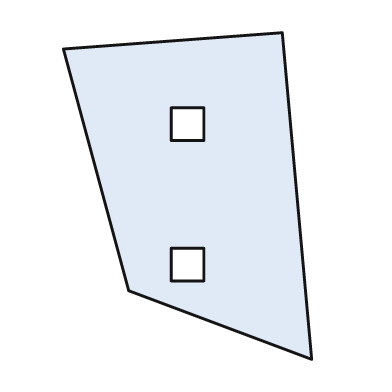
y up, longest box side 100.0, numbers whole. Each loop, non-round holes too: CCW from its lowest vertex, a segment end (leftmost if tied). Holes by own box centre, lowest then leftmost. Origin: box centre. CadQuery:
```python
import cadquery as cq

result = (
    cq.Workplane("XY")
    .moveTo(38.0, -50.0)
    .lineTo(29.0, 50.0)
    .lineTo(-38.0, 45.0)
    .lineTo(-18.0, -29.0)
    .close()
    .moveTo(-5.0, -26.0)
    .lineTo(5.0, -26.0)
    .lineTo(5.0, -16.0)
    .lineTo(-5.0, -16.0)
    .close()
    .moveTo(-5.0, 17.0)
    .lineTo(5.0, 17.0)
    .lineTo(5.0, 27.0)
    .lineTo(-5.0, 27.0)
    .close()
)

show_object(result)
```